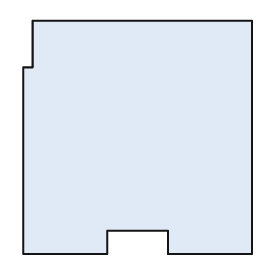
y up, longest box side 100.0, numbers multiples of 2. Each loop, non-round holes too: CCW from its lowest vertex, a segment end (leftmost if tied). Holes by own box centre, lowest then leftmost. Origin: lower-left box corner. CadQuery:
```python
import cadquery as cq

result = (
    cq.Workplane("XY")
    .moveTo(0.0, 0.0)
    .lineTo(36.0, 0.0)
    .lineTo(36.0, 10.0)
    .lineTo(62.0, 10.0)
    .lineTo(62.0, 0.0)
    .lineTo(98.0, 0.0)
    .lineTo(98.0, 100.0)
    .lineTo(4.0, 100.0)
    .lineTo(4.0, 80.0)
    .lineTo(0.0, 80.0)
    .close()
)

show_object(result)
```